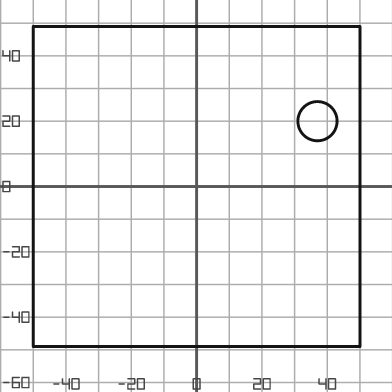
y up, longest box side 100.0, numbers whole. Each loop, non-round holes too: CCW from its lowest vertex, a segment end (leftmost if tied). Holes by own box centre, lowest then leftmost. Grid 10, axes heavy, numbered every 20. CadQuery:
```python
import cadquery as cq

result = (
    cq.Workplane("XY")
    .moveTo(-50.0, -49.0)
    .lineTo(50.0, -49.0)
    .lineTo(50.0, 49.0)
    .lineTo(-50.0, 49.0)
    .close()
    .moveTo(37.0, 20.0)
    .circle(6.0)
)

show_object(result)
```